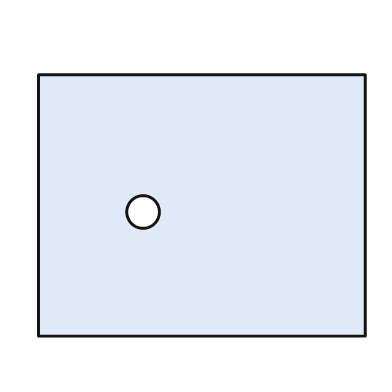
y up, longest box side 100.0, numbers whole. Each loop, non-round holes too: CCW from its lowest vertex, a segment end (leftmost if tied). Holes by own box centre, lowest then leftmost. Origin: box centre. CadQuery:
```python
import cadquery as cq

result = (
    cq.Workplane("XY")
    .moveTo(-50.0, -40.0)
    .lineTo(50.0, -40.0)
    .lineTo(50.0, 40.0)
    .lineTo(-50.0, 40.0)
    .close()
    .moveTo(-18.0, -2.0)
    .circle(5.0)
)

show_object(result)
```